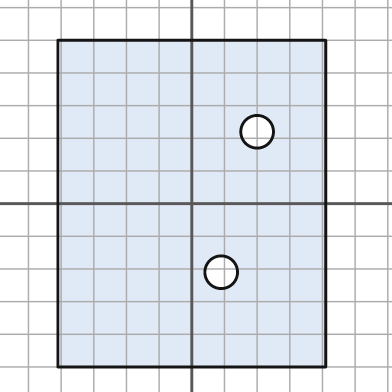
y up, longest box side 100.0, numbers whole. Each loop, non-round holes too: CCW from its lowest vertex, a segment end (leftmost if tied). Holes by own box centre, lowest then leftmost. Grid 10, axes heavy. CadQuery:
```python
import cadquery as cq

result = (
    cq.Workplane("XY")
    .moveTo(-41.0, -50.0)
    .lineTo(41.0, -50.0)
    .lineTo(41.0, 50.0)
    .lineTo(-41.0, 50.0)
    .close()
    .moveTo(9.0, -21.0)
    .circle(5.0)
    .moveTo(20.0, 22.0)
    .circle(5.0)
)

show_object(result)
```